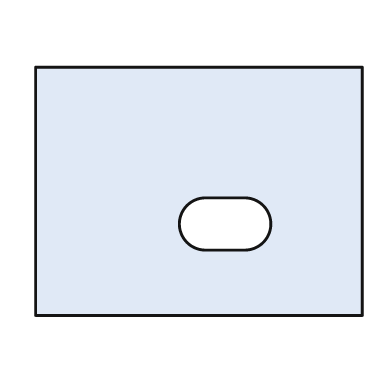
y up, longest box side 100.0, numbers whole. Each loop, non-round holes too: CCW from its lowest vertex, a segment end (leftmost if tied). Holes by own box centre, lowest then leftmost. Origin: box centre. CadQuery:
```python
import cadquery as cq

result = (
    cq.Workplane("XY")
    .moveTo(-50.0, -38.0)
    .lineTo(50.0, -38.0)
    .lineTo(50.0, 38.0)
    .lineTo(-50.0, 38.0)
    .close()
    .moveTo(2.0, -18.0)
    .lineTo(14.0, -18.0)
    .threePointArc((22.0, -10.0), (14.0, -2.0))
    .lineTo(2.0, -2.0)
    .threePointArc((-6.0, -10.0), (2.0, -18.0))
    .close()
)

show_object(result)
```